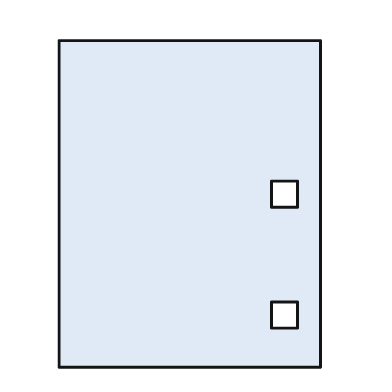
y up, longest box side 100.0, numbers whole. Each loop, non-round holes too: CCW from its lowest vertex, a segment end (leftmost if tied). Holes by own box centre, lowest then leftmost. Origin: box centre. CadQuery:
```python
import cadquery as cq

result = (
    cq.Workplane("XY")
    .moveTo(-40.0, -50.0)
    .lineTo(40.0, -50.0)
    .lineTo(40.0, 50.0)
    .lineTo(-40.0, 50.0)
    .close()
    .moveTo(25.0, -38.0)
    .lineTo(33.0, -38.0)
    .lineTo(33.0, -30.0)
    .lineTo(25.0, -30.0)
    .close()
    .moveTo(25.0, -1.0)
    .lineTo(33.0, -1.0)
    .lineTo(33.0, 7.0)
    .lineTo(25.0, 7.0)
    .close()
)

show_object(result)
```